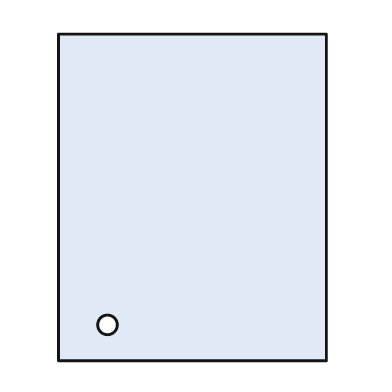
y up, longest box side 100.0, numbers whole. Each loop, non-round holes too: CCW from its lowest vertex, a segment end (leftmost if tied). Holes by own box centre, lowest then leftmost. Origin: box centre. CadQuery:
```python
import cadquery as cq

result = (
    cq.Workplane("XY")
    .moveTo(-41.0, -50.0)
    .lineTo(41.0, -50.0)
    .lineTo(41.0, 50.0)
    .lineTo(-41.0, 50.0)
    .close()
    .moveTo(-26.0, -39.0)
    .circle(3.0)
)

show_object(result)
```